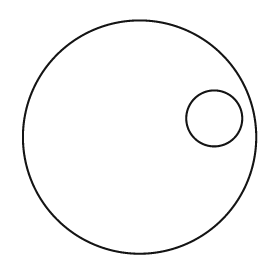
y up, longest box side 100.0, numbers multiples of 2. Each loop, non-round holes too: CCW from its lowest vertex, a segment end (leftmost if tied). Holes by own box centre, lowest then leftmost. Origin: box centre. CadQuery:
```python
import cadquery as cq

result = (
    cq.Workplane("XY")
    .moveTo(0.0, 0.0)
    .circle(50.0)
    .moveTo(32.0, 8.0)
    .circle(12.0)
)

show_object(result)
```